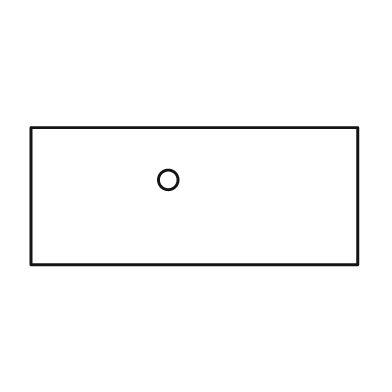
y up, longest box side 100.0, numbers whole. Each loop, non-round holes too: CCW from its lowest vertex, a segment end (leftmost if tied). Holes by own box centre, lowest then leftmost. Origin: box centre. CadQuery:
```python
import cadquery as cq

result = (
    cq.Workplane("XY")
    .moveTo(-50.0, -21.0)
    .lineTo(50.0, -21.0)
    .lineTo(50.0, 21.0)
    .lineTo(-50.0, 21.0)
    .close()
    .moveTo(-8.0, 5.0)
    .circle(3.0)
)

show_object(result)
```